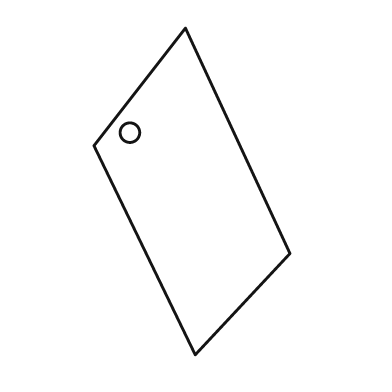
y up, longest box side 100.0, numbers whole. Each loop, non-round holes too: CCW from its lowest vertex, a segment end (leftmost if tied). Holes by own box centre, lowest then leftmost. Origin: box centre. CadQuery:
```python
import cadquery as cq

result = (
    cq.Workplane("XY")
    .moveTo(1.0, -50.0)
    .lineTo(30.0, -19.0)
    .lineTo(-2.0, 50.0)
    .lineTo(-30.0, 14.0)
    .close()
    .moveTo(-19.0, 18.0)
    .circle(3.0)
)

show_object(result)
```